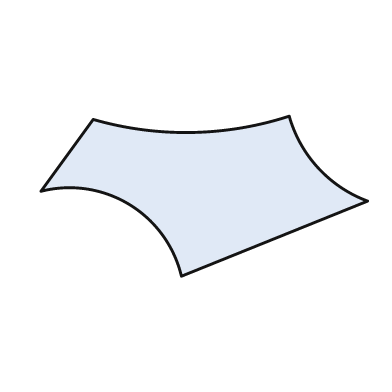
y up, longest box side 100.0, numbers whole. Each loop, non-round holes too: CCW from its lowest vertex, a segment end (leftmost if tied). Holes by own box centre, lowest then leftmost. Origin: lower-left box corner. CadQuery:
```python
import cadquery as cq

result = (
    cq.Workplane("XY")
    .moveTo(43.0, 0.0)
    .lineTo(100.0, 23.0)
    .threePointArc((85.0, 33.0), (76.0, 49.0))
    .threePointArc((46.0, 44.0), (16.0, 48.0))
    .lineTo(0.0, 26.0)
    .threePointArc((27.0, 22.0), (43.0, 0.0))
    .close()
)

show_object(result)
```